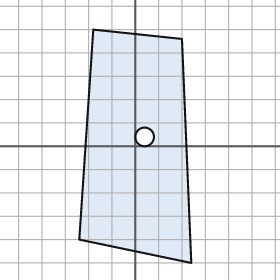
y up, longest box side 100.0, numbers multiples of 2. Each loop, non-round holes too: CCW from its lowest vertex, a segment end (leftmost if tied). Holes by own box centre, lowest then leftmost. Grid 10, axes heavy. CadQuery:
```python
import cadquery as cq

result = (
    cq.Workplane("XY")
    .moveTo(24.0, -50.0)
    .lineTo(20.0, 46.0)
    .lineTo(-18.0, 50.0)
    .lineTo(-24.0, -40.0)
    .close()
    .moveTo(4.0, 4.0)
    .circle(4.0)
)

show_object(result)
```